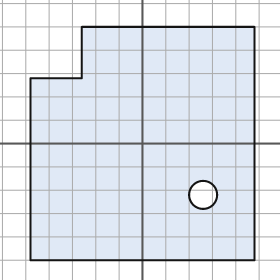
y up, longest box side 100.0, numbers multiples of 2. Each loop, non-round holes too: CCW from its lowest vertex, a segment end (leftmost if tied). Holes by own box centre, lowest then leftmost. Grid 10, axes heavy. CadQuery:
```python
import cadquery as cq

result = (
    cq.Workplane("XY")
    .moveTo(-48.0, -50.0)
    .lineTo(48.0, -50.0)
    .lineTo(48.0, 50.0)
    .lineTo(-26.0, 50.0)
    .lineTo(-26.0, 28.0)
    .lineTo(-48.0, 28.0)
    .close()
    .moveTo(26.0, -22.0)
    .circle(6.0)
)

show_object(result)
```